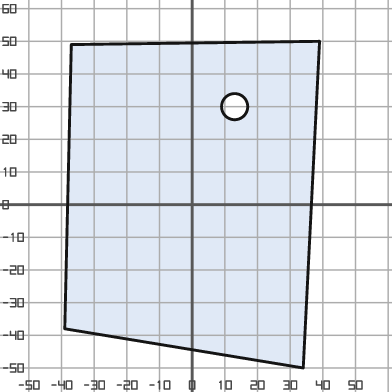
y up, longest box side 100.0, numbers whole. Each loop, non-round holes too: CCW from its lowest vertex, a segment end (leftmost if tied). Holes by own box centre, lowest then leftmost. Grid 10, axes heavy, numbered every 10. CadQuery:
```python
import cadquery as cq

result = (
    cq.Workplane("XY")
    .moveTo(34.0, -50.0)
    .lineTo(39.0, 50.0)
    .lineTo(-37.0, 49.0)
    .lineTo(-39.0, -38.0)
    .close()
    .moveTo(13.0, 30.0)
    .circle(4.0)
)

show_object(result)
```